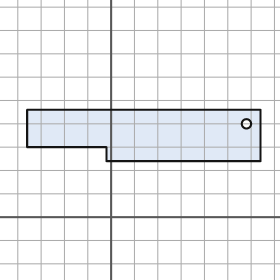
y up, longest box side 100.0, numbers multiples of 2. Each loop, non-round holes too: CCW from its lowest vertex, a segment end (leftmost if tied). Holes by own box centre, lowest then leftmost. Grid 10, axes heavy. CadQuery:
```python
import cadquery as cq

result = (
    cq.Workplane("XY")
    .moveTo(-2.0, 24.0)
    .lineTo(64.0, 24.0)
    .lineTo(64.0, 46.0)
    .lineTo(-36.0, 46.0)
    .lineTo(-36.0, 30.0)
    .lineTo(-2.0, 30.0)
    .close()
    .moveTo(58.0, 40.0)
    .circle(2.0)
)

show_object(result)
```